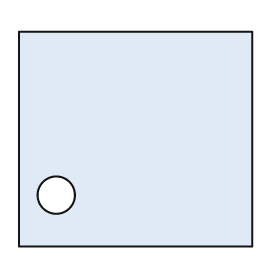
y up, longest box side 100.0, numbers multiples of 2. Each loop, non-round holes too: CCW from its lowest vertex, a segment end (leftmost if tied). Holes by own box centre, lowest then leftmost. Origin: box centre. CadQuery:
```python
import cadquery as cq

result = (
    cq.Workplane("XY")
    .moveTo(-50.0, -46.0)
    .lineTo(50.0, -46.0)
    .lineTo(50.0, 46.0)
    .lineTo(-50.0, 46.0)
    .close()
    .moveTo(-34.0, -24.0)
    .circle(8.0)
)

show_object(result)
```